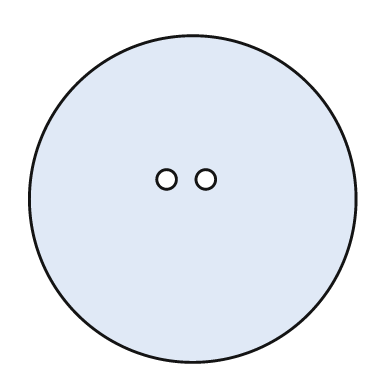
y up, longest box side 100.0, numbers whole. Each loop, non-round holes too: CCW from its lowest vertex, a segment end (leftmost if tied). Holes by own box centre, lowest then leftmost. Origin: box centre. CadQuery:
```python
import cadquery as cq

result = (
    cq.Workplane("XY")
    .moveTo(0.0, 0.0)
    .circle(50.0)
    .moveTo(-8.0, 6.0)
    .circle(3.0)
    .moveTo(4.0, 6.0)
    .circle(3.0)
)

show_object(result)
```